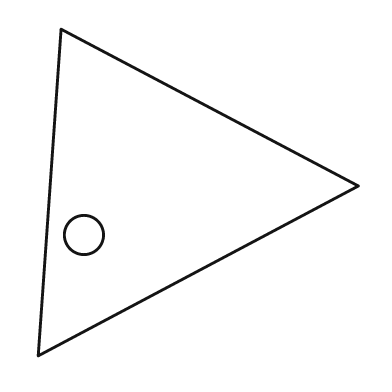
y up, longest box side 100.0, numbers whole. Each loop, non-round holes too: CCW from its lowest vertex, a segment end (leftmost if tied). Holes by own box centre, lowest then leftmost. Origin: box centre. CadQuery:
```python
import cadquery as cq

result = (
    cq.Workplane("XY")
    .moveTo(-49.0, -50.0)
    .lineTo(49.0, 2.0)
    .lineTo(-42.0, 50.0)
    .close()
    .moveTo(-35.0, -13.0)
    .circle(6.0)
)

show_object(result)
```